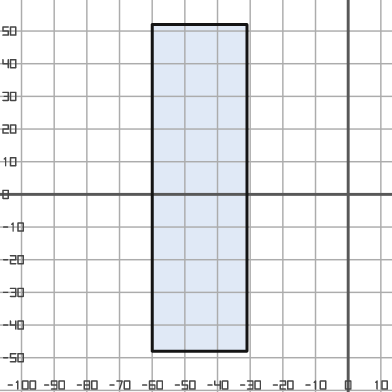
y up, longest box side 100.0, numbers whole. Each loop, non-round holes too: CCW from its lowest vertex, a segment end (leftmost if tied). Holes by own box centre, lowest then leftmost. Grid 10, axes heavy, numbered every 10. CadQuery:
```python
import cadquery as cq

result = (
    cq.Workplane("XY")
    .moveTo(-60.0, -48.0)
    .lineTo(-31.0, -48.0)
    .lineTo(-31.0, 52.0)
    .lineTo(-60.0, 52.0)
    .close()
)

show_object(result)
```